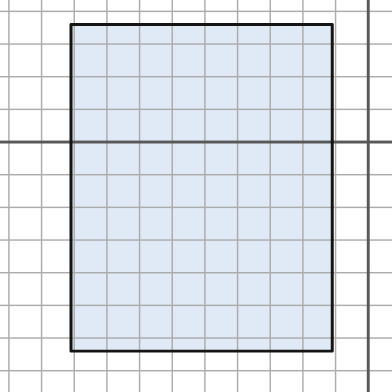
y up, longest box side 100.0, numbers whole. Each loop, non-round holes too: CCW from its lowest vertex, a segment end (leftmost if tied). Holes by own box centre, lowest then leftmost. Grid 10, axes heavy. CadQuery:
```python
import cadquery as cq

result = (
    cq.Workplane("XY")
    .moveTo(-91.0, -64.0)
    .lineTo(-11.0, -64.0)
    .lineTo(-11.0, 36.0)
    .lineTo(-91.0, 36.0)
    .close()
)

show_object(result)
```